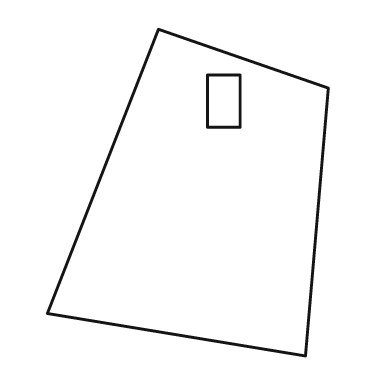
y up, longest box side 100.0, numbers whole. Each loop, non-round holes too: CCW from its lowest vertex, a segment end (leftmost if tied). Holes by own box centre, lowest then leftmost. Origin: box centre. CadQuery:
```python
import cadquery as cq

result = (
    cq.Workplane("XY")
    .moveTo(36.0, -50.0)
    .lineTo(43.0, 32.0)
    .lineTo(-9.0, 50.0)
    .lineTo(-43.0, -37.0)
    .close()
    .moveTo(6.0, 20.0)
    .lineTo(16.0, 20.0)
    .lineTo(16.0, 36.0)
    .lineTo(6.0, 36.0)
    .close()
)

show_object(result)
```